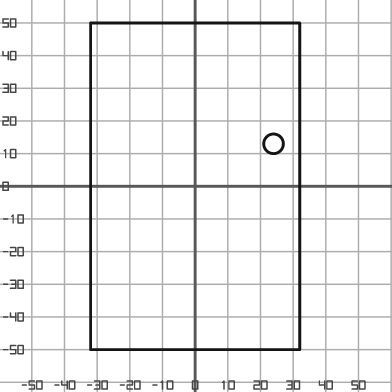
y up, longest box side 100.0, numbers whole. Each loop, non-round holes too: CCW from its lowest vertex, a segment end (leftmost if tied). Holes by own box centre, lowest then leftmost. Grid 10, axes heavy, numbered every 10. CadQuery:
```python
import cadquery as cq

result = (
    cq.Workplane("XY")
    .moveTo(-32.0, -50.0)
    .lineTo(32.0, -50.0)
    .lineTo(32.0, 50.0)
    .lineTo(-32.0, 50.0)
    .close()
    .moveTo(24.0, 13.0)
    .circle(3.0)
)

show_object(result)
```